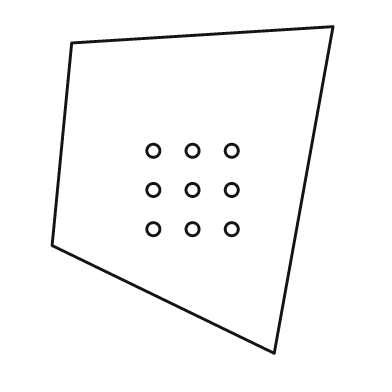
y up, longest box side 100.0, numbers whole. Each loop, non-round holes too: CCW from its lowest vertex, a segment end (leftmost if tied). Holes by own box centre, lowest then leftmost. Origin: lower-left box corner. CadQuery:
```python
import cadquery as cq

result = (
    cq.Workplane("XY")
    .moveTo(68.0, 0.0)
    .lineTo(86.0, 100.0)
    .lineTo(6.0, 95.0)
    .lineTo(0.0, 33.0)
    .close()
    .moveTo(31.0, 38.0)
    .circle(2.0)
    .moveTo(43.0, 38.0)
    .circle(2.0)
    .moveTo(55.0, 38.0)
    .circle(2.0)
    .moveTo(31.0, 50.0)
    .circle(2.0)
    .moveTo(43.0, 50.0)
    .circle(2.0)
    .moveTo(55.0, 50.0)
    .circle(2.0)
    .moveTo(31.0, 62.0)
    .circle(2.0)
    .moveTo(43.0, 62.0)
    .circle(2.0)
    .moveTo(55.0, 62.0)
    .circle(2.0)
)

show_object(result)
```